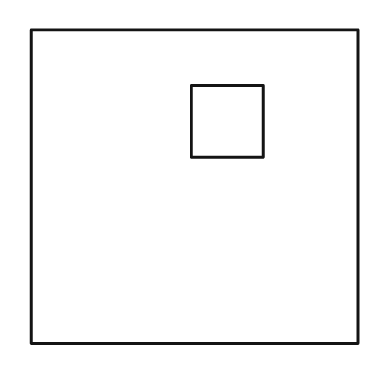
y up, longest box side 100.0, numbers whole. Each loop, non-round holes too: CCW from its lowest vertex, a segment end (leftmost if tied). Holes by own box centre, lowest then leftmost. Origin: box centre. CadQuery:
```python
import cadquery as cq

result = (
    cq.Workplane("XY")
    .moveTo(-50.0, -48.0)
    .lineTo(50.0, -48.0)
    .lineTo(50.0, 48.0)
    .lineTo(-50.0, 48.0)
    .close()
    .moveTo(-1.0, 9.0)
    .lineTo(21.0, 9.0)
    .lineTo(21.0, 31.0)
    .lineTo(-1.0, 31.0)
    .close()
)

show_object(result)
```